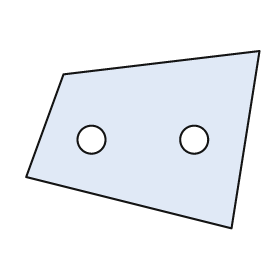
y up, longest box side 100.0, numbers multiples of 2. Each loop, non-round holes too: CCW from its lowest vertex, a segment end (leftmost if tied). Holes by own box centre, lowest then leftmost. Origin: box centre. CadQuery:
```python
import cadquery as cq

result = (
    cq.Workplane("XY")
    .moveTo(38.0, -38.0)
    .lineTo(50.0, 38.0)
    .lineTo(-34.0, 28.0)
    .lineTo(-50.0, -16.0)
    .close()
    .moveTo(-22.0, 0.0)
    .circle(6.0)
    .moveTo(22.0, 0.0)
    .circle(6.0)
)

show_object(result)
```